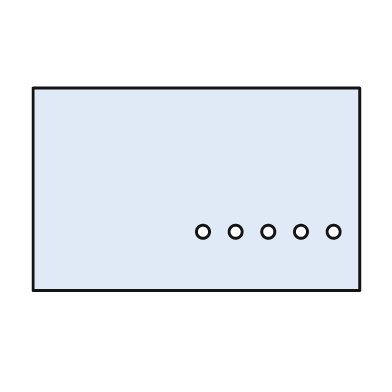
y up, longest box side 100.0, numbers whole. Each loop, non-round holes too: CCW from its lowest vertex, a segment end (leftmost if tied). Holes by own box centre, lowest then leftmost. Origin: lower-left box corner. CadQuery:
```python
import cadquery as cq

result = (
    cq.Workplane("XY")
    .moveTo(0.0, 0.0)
    .lineTo(100.0, 0.0)
    .lineTo(100.0, 62.0)
    .lineTo(0.0, 62.0)
    .close()
    .moveTo(52.0, 18.0)
    .circle(2.0)
    .moveTo(62.0, 18.0)
    .circle(2.0)
    .moveTo(72.0, 18.0)
    .circle(2.0)
    .moveTo(82.0, 18.0)
    .circle(2.0)
    .moveTo(92.0, 18.0)
    .circle(2.0)
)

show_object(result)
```